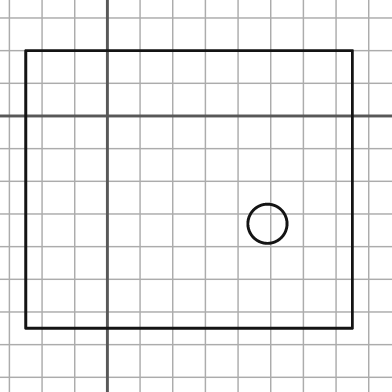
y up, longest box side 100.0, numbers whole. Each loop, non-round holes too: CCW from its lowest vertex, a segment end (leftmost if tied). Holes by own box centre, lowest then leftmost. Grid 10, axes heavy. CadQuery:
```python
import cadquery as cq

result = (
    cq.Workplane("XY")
    .moveTo(-25.0, -65.0)
    .lineTo(75.0, -65.0)
    .lineTo(75.0, 20.0)
    .lineTo(-25.0, 20.0)
    .close()
    .moveTo(49.0, -33.0)
    .circle(6.0)
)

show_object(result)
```